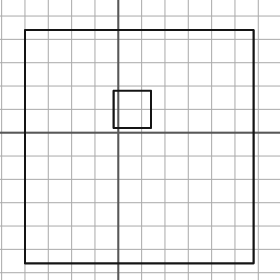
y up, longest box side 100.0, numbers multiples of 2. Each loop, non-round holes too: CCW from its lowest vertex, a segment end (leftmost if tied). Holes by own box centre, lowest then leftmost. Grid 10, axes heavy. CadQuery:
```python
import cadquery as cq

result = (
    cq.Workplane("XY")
    .moveTo(-40.0, -56.0)
    .lineTo(58.0, -56.0)
    .lineTo(58.0, 44.0)
    .lineTo(-40.0, 44.0)
    .close()
    .moveTo(-2.0, 2.0)
    .lineTo(14.0, 2.0)
    .lineTo(14.0, 18.0)
    .lineTo(-2.0, 18.0)
    .close()
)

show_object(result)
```